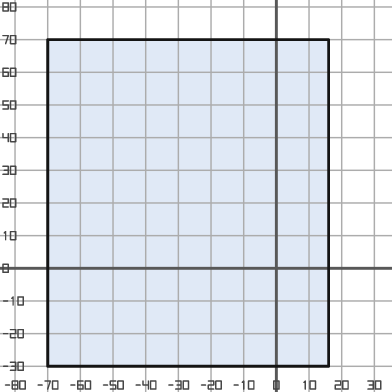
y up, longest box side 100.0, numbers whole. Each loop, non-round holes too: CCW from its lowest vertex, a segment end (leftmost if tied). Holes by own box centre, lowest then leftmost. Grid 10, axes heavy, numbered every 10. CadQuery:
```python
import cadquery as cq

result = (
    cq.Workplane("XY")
    .moveTo(-70.0, -30.0)
    .lineTo(16.0, -30.0)
    .lineTo(16.0, 70.0)
    .lineTo(-70.0, 70.0)
    .close()
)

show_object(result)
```